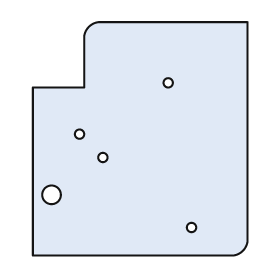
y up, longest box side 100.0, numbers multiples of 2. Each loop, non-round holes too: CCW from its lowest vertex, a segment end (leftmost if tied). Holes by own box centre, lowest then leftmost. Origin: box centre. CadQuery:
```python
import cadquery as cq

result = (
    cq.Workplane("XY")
    .moveTo(-46.0, -50.0)
    .lineTo(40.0, -50.0)
    .threePointArc((44.0, -48.0), (46.0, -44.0))
    .lineTo(46.0, 50.0)
    .lineTo(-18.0, 50.0)
    .threePointArc((-22.0, 48.0), (-24.0, 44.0))
    .lineTo(-24.0, 22.0)
    .lineTo(-46.0, 22.0)
    .close()
    .moveTo(22.0, -38.0)
    .circle(2.0)
    .moveTo(-38.0, -24.0)
    .circle(4.0)
    .moveTo(-16.0, -8.0)
    .circle(2.0)
    .moveTo(-26.0, 2.0)
    .circle(2.0)
    .moveTo(12.0, 24.0)
    .circle(2.0)
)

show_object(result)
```